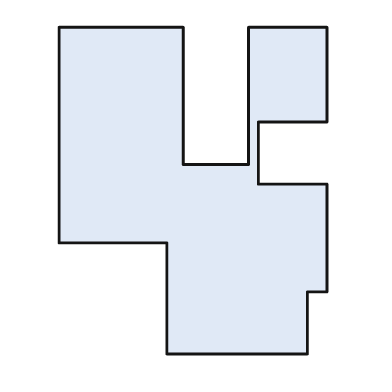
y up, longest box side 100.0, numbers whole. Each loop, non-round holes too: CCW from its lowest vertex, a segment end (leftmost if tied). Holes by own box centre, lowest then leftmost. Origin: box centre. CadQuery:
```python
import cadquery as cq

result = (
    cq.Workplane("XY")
    .moveTo(-8.0, -50.0)
    .lineTo(35.0, -50.0)
    .lineTo(35.0, -31.0)
    .lineTo(41.0, -31.0)
    .lineTo(41.0, 2.0)
    .lineTo(20.0, 2.0)
    .lineTo(20.0, 21.0)
    .lineTo(41.0, 21.0)
    .lineTo(41.0, 50.0)
    .lineTo(17.0, 50.0)
    .lineTo(17.0, 8.0)
    .lineTo(-3.0, 8.0)
    .lineTo(-3.0, 50.0)
    .lineTo(-41.0, 50.0)
    .lineTo(-41.0, -16.0)
    .lineTo(-8.0, -16.0)
    .close()
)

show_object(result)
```